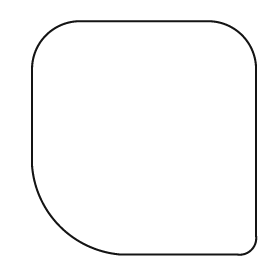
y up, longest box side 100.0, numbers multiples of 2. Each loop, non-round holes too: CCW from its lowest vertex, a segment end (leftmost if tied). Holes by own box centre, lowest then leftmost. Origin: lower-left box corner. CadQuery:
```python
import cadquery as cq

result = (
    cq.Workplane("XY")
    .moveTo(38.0, 0.0)
    .lineTo(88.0, 0.0)
    .threePointArc((94.0, 2.0), (96.0, 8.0))
    .lineTo(96.0, 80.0)
    .threePointArc((90.0, 94.0), (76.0, 100.0))
    .lineTo(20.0, 100.0)
    .threePointArc((6.0, 94.0), (0.0, 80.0))
    .lineTo(0.0, 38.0)
    .threePointArc((12.0, 12.0), (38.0, 0.0))
    .close()
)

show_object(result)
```